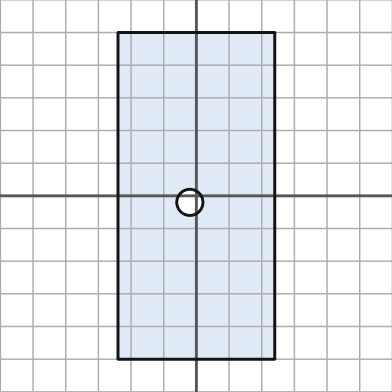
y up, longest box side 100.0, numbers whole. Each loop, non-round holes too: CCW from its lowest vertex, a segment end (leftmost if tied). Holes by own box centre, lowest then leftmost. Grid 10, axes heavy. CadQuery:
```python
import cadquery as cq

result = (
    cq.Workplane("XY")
    .moveTo(-24.0, -50.0)
    .lineTo(24.0, -50.0)
    .lineTo(24.0, 50.0)
    .lineTo(-24.0, 50.0)
    .close()
    .moveTo(-2.0, -2.0)
    .circle(4.0)
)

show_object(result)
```